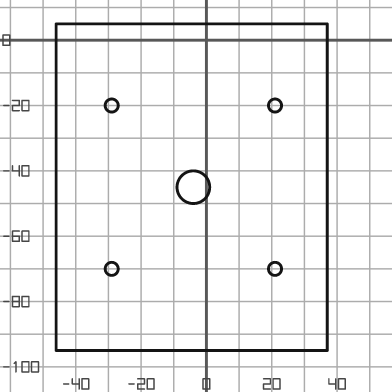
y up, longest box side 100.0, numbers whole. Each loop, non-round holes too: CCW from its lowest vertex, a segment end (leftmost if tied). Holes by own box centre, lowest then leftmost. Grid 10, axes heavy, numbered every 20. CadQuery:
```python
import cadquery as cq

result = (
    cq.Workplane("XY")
    .moveTo(-46.0, -95.0)
    .lineTo(37.0, -95.0)
    .lineTo(37.0, 5.0)
    .lineTo(-46.0, 5.0)
    .close()
    .moveTo(-29.0, -70.0)
    .circle(2.0)
    .moveTo(21.0, -70.0)
    .circle(2.0)
    .moveTo(-4.0, -45.0)
    .circle(5.0)
    .moveTo(-29.0, -20.0)
    .circle(2.0)
    .moveTo(21.0, -20.0)
    .circle(2.0)
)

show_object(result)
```